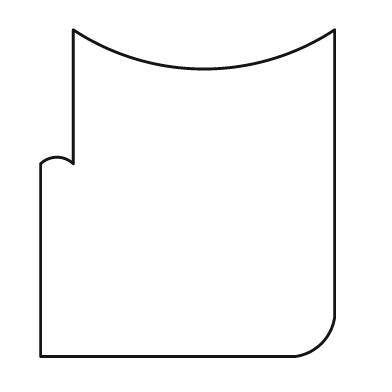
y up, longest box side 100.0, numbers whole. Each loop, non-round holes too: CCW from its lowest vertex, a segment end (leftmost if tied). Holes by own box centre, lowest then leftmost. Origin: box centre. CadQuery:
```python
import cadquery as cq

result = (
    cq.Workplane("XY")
    .moveTo(-45.0, -50.0)
    .lineTo(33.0, -50.0)
    .threePointArc((41.0, -46.0), (45.0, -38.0))
    .lineTo(45.0, 50.0)
    .threePointArc((5.0, 38.0), (-35.0, 50.0))
    .lineTo(-35.0, 9.0)
    .threePointArc((-40.0, 11.0), (-45.0, 9.0))
    .close()
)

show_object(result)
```